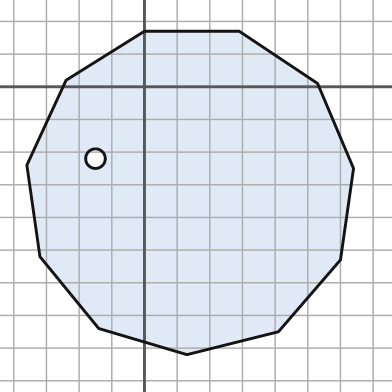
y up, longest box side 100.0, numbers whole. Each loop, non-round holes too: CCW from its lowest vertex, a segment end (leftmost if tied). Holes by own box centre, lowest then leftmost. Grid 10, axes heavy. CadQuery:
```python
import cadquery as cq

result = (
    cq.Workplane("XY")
    .moveTo(13.0, -82.0)
    .lineTo(41.0, -75.0)
    .lineTo(60.0, -53.0)
    .lineTo(64.0, -25.0)
    .lineTo(53.0, 1.0)
    .lineTo(29.0, 17.0)
    .lineTo(0.0, 17.0)
    .lineTo(-24.0, 2.0)
    .lineTo(-36.0, -24.0)
    .lineTo(-32.0, -52.0)
    .lineTo(-14.0, -74.0)
    .close()
    .moveTo(-15.0, -22.0)
    .circle(3.0)
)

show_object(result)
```